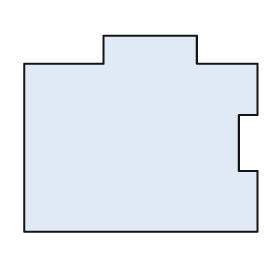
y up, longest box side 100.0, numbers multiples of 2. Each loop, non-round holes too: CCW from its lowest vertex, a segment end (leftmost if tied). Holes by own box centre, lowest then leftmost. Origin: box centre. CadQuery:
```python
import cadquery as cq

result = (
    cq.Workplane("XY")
    .moveTo(-50.0, -42.0)
    .lineTo(50.0, -42.0)
    .lineTo(50.0, -16.0)
    .lineTo(42.0, -16.0)
    .lineTo(42.0, 8.0)
    .lineTo(50.0, 8.0)
    .lineTo(50.0, 30.0)
    .lineTo(24.0, 30.0)
    .lineTo(24.0, 42.0)
    .lineTo(-16.0, 42.0)
    .lineTo(-16.0, 30.0)
    .lineTo(-50.0, 30.0)
    .close()
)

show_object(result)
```